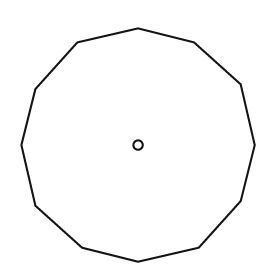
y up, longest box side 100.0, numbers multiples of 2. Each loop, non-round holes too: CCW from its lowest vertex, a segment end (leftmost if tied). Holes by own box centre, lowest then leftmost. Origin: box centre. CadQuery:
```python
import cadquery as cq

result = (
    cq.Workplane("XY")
    .moveTo(0.0, -50.0)
    .lineTo(26.0, -44.0)
    .lineTo(44.0, -24.0)
    .lineTo(50.0, 0.0)
    .lineTo(44.0, 26.0)
    .lineTo(24.0, 44.0)
    .lineTo(0.0, 50.0)
    .lineTo(-26.0, 44.0)
    .lineTo(-44.0, 24.0)
    .lineTo(-50.0, 0.0)
    .lineTo(-44.0, -26.0)
    .lineTo(-24.0, -44.0)
    .close()
    .moveTo(0.0, 0.0)
    .circle(2.0)
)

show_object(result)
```